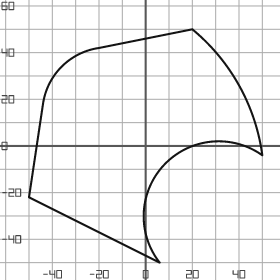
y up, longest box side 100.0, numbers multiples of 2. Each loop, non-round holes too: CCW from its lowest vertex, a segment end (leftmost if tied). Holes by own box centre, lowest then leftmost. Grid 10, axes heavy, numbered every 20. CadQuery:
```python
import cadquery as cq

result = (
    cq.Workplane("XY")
    .moveTo(6.0, -50.0)
    .threePointArc((8.0, -8.0), (50.0, -4.0))
    .threePointArc((40.0, 26.0), (20.0, 50.0))
    .lineTo(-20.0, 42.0)
    .threePointArc((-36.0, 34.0), (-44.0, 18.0))
    .lineTo(-50.0, -22.0)
    .close()
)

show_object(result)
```